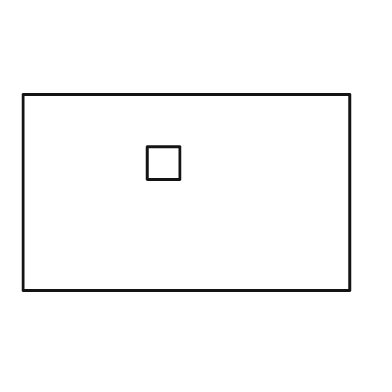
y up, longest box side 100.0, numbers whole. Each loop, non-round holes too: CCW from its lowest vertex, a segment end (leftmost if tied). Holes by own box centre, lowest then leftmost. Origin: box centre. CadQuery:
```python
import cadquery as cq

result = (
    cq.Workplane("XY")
    .moveTo(-50.0, -30.0)
    .lineTo(50.0, -30.0)
    .lineTo(50.0, 30.0)
    .lineTo(-50.0, 30.0)
    .close()
    .moveTo(-12.0, 4.0)
    .lineTo(-2.0, 4.0)
    .lineTo(-2.0, 14.0)
    .lineTo(-12.0, 14.0)
    .close()
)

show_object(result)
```